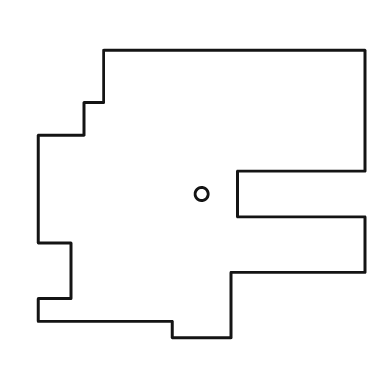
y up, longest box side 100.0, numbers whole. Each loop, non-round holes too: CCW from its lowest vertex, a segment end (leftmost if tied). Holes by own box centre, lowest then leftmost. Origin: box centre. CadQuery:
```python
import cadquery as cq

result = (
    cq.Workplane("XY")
    .moveTo(-9.0, -44.0)
    .lineTo(9.0, -44.0)
    .lineTo(9.0, -24.0)
    .lineTo(50.0, -24.0)
    .lineTo(50.0, -7.0)
    .lineTo(11.0, -7.0)
    .lineTo(11.0, 7.0)
    .lineTo(50.0, 7.0)
    .lineTo(50.0, 44.0)
    .lineTo(-30.0, 44.0)
    .lineTo(-30.0, 28.0)
    .lineTo(-36.0, 28.0)
    .lineTo(-36.0, 18.0)
    .lineTo(-50.0, 18.0)
    .lineTo(-50.0, -15.0)
    .lineTo(-40.0, -15.0)
    .lineTo(-40.0, -32.0)
    .lineTo(-50.0, -32.0)
    .lineTo(-50.0, -39.0)
    .lineTo(-9.0, -39.0)
    .close()
    .moveTo(0.0, 0.0)
    .circle(2.0)
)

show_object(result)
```